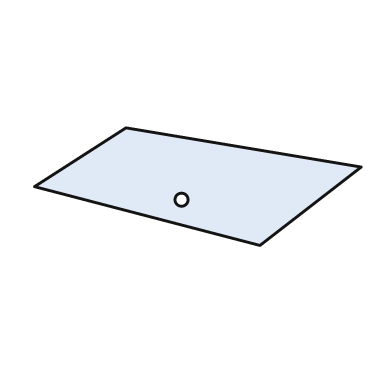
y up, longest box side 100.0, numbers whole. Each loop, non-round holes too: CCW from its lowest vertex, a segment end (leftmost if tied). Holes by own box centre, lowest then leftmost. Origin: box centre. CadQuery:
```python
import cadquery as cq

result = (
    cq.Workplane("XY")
    .moveTo(19.0, -18.0)
    .lineTo(50.0, 6.0)
    .lineTo(-22.0, 18.0)
    .lineTo(-50.0, 0.0)
    .close()
    .moveTo(-5.0, -4.0)
    .circle(2.0)
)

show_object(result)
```